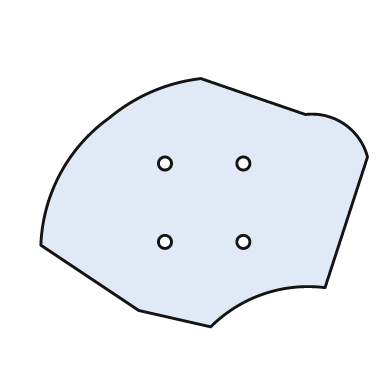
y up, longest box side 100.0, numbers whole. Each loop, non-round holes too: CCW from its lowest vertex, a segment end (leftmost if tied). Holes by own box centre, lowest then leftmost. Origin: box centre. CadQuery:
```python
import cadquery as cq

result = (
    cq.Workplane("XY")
    .moveTo(2.0, -38.0)
    .threePointArc((18.0, -28.0), (37.0, -26.0))
    .lineTo(50.0, 14.0)
    .threePointArc((43.0, 24.0), (31.0, 27.0))
    .lineTo(-1.0, 38.0)
    .threePointArc((-16.0, 34.0), (-29.0, 26.0))
    .threePointArc((-44.0, 9.0), (-50.0, -13.0))
    .lineTo(-20.0, -33.0)
    .close()
    .moveTo(-12.0, -12.0)
    .circle(2.0)
    .moveTo(12.0, -12.0)
    .circle(2.0)
    .moveTo(-12.0, 12.0)
    .circle(2.0)
    .moveTo(12.0, 12.0)
    .circle(2.0)
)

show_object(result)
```